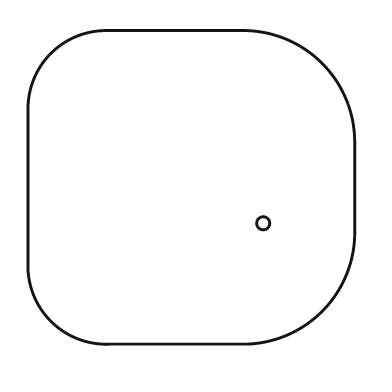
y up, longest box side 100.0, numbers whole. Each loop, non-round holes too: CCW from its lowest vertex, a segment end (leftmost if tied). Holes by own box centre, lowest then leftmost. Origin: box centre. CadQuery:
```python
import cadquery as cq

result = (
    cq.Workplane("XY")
    .moveTo(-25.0, -48.0)
    .lineTo(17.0, -48.0)
    .threePointArc((40.0, -38.0), (50.0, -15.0))
    .lineTo(50.0, 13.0)
    .threePointArc((40.0, 38.0), (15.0, 48.0))
    .lineTo(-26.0, 48.0)
    .threePointArc((-43.0, 41.0), (-50.0, 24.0))
    .lineTo(-50.0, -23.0)
    .threePointArc((-43.0, -41.0), (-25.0, -48.0))
    .close()
    .moveTo(22.0, -11.0)
    .circle(2.0)
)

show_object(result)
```